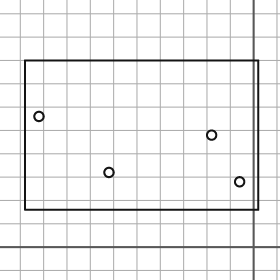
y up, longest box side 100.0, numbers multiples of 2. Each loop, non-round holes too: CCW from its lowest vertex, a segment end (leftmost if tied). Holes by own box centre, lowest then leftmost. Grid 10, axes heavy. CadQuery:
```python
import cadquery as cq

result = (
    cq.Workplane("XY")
    .moveTo(-98.0, 16.0)
    .lineTo(2.0, 16.0)
    .lineTo(2.0, 80.0)
    .lineTo(-98.0, 80.0)
    .close()
    .moveTo(-6.0, 28.0)
    .circle(2.0)
    .moveTo(-62.0, 32.0)
    .circle(2.0)
    .moveTo(-18.0, 48.0)
    .circle(2.0)
    .moveTo(-92.0, 56.0)
    .circle(2.0)
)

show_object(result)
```